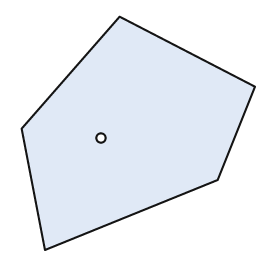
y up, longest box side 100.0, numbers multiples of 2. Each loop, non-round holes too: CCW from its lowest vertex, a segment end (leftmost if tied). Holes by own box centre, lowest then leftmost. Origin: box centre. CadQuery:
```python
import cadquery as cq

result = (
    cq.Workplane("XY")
    .moveTo(-40.0, -50.0)
    .lineTo(34.0, -20.0)
    .lineTo(50.0, 20.0)
    .lineTo(-8.0, 50.0)
    .lineTo(-50.0, 2.0)
    .close()
    .moveTo(-16.0, -2.0)
    .circle(2.0)
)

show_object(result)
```